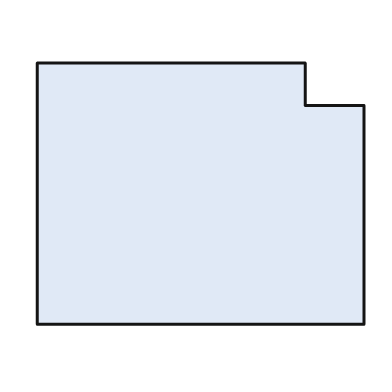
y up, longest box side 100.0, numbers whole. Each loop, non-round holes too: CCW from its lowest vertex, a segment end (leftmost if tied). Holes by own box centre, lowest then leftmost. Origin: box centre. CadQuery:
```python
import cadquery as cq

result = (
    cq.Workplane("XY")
    .moveTo(-50.0, -40.0)
    .lineTo(50.0, -40.0)
    .lineTo(50.0, 27.0)
    .lineTo(32.0, 27.0)
    .lineTo(32.0, 40.0)
    .lineTo(-50.0, 40.0)
    .close()
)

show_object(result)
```